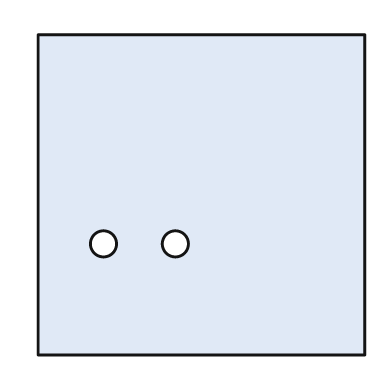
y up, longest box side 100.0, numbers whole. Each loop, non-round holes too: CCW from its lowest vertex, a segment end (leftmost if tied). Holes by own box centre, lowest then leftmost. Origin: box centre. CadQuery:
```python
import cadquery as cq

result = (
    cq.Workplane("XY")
    .moveTo(-50.0, -49.0)
    .lineTo(50.0, -49.0)
    .lineTo(50.0, 49.0)
    .lineTo(-50.0, 49.0)
    .close()
    .moveTo(-30.0, -15.0)
    .circle(4.0)
    .moveTo(-8.0, -15.0)
    .circle(4.0)
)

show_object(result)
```